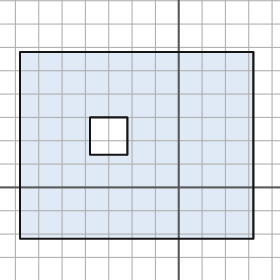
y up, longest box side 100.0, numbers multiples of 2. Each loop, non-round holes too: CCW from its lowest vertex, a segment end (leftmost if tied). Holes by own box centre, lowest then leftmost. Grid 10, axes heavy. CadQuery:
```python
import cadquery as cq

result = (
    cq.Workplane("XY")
    .moveTo(-68.0, -22.0)
    .lineTo(32.0, -22.0)
    .lineTo(32.0, 58.0)
    .lineTo(-68.0, 58.0)
    .close()
    .moveTo(-38.0, 14.0)
    .lineTo(-22.0, 14.0)
    .lineTo(-22.0, 30.0)
    .lineTo(-38.0, 30.0)
    .close()
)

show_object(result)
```